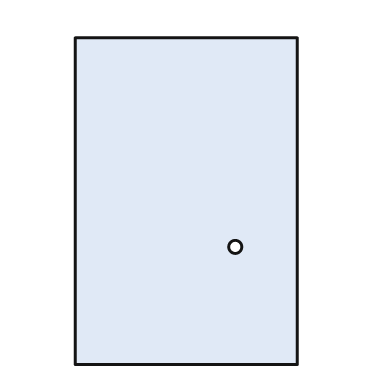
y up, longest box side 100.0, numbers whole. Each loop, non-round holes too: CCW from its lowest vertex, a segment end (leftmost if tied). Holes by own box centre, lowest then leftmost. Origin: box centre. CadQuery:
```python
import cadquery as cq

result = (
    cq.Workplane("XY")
    .moveTo(-34.0, -50.0)
    .lineTo(34.0, -50.0)
    .lineTo(34.0, 50.0)
    .lineTo(-34.0, 50.0)
    .close()
    .moveTo(15.0, -14.0)
    .circle(2.0)
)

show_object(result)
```